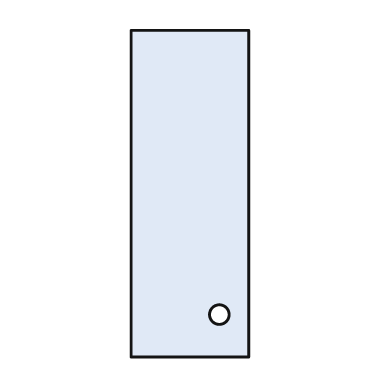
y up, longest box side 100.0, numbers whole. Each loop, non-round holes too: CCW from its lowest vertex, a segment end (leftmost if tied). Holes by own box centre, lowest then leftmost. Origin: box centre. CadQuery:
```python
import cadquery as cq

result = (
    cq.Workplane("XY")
    .moveTo(-18.0, -50.0)
    .lineTo(18.0, -50.0)
    .lineTo(18.0, 50.0)
    .lineTo(-18.0, 50.0)
    .close()
    .moveTo(9.0, -37.0)
    .circle(3.0)
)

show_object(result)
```